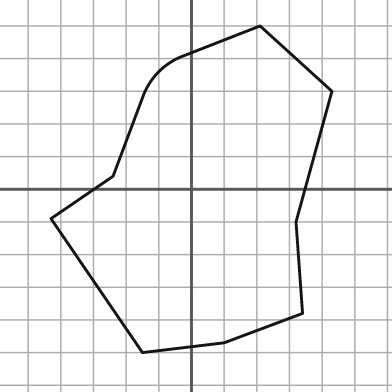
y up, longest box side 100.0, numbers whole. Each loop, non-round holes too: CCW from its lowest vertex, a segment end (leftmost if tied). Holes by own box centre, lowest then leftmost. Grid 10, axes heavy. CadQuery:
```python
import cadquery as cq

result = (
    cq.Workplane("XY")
    .moveTo(-15.0, -50.0)
    .lineTo(10.0, -47.0)
    .lineTo(34.0, -38.0)
    .lineTo(32.0, -10.0)
    .lineTo(43.0, 30.0)
    .lineTo(21.0, 50.0)
    .lineTo(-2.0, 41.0)
    .threePointArc((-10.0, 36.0), (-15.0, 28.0))
    .lineTo(-24.0, 4.0)
    .lineTo(-43.0, -9.0)
    .close()
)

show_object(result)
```